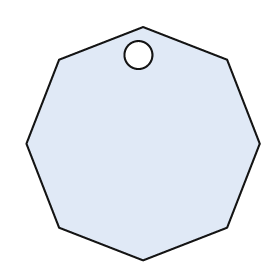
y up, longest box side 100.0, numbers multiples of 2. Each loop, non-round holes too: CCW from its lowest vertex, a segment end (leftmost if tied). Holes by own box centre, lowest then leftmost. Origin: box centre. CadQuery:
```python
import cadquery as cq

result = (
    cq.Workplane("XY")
    .moveTo(0.0, -50.0)
    .lineTo(36.0, -36.0)
    .lineTo(50.0, 0.0)
    .lineTo(36.0, 36.0)
    .lineTo(0.0, 50.0)
    .lineTo(-36.0, 36.0)
    .lineTo(-50.0, 0.0)
    .lineTo(-36.0, -36.0)
    .close()
    .moveTo(-2.0, 38.0)
    .circle(6.0)
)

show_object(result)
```